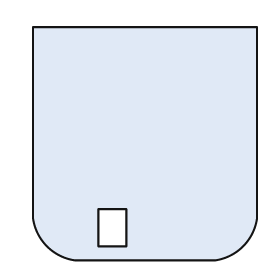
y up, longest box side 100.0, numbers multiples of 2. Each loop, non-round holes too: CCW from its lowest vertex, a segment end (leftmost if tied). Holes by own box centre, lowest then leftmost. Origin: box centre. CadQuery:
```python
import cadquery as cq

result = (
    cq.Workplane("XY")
    .moveTo(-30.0, -50.0)
    .lineTo(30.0, -50.0)
    .threePointArc((42.0, -44.0), (48.0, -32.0))
    .lineTo(48.0, 50.0)
    .lineTo(-48.0, 50.0)
    .lineTo(-48.0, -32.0)
    .threePointArc((-42.0, -44.0), (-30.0, -50.0))
    .close()
    .moveTo(-20.0, -44.0)
    .lineTo(-8.0, -44.0)
    .lineTo(-8.0, -28.0)
    .lineTo(-20.0, -28.0)
    .close()
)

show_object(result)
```